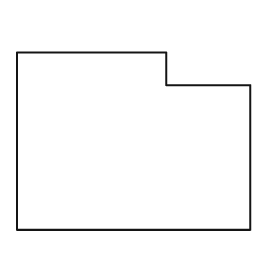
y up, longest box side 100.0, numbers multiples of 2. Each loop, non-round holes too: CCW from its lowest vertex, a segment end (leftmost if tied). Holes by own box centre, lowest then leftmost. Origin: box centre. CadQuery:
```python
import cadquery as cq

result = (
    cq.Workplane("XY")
    .moveTo(-50.0, -38.0)
    .lineTo(50.0, -38.0)
    .lineTo(50.0, 24.0)
    .lineTo(14.0, 24.0)
    .lineTo(14.0, 38.0)
    .lineTo(-50.0, 38.0)
    .close()
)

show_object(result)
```